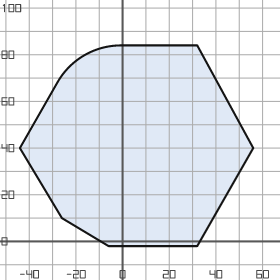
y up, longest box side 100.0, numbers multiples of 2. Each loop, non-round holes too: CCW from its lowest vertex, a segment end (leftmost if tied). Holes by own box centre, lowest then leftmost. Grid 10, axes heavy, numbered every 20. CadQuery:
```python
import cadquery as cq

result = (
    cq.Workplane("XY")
    .moveTo(-6.0, -2.0)
    .lineTo(32.0, -2.0)
    .lineTo(56.0, 40.0)
    .lineTo(32.0, 84.0)
    .lineTo(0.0, 84.0)
    .threePointArc((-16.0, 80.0), (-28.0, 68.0))
    .lineTo(-44.0, 40.0)
    .lineTo(-26.0, 10.0)
    .close()
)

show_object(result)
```